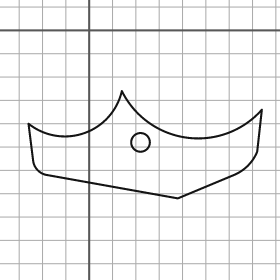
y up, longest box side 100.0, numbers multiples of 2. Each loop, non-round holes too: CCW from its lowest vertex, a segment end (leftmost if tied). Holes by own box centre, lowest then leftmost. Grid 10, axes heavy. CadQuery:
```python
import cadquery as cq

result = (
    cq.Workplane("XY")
    .moveTo(38.0, -72.0)
    .lineTo(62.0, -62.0)
    .threePointArc((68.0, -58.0), (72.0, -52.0))
    .lineTo(74.0, -34.0)
    .threePointArc((42.0, -46.0), (14.0, -26.0))
    .threePointArc((-2.0, -44.0), (-26.0, -40.0))
    .lineTo(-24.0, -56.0)
    .threePointArc((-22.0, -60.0), (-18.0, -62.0))
    .close()
    .moveTo(22.0, -48.0)
    .circle(4.0)
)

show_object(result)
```